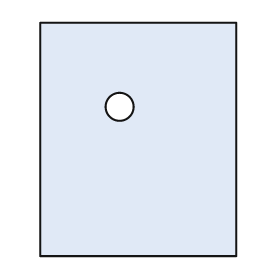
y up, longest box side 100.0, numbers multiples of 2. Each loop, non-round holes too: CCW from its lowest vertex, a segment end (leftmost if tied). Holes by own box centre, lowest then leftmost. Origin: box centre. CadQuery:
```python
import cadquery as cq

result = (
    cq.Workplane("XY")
    .moveTo(-42.0, -50.0)
    .lineTo(42.0, -50.0)
    .lineTo(42.0, 50.0)
    .lineTo(-42.0, 50.0)
    .close()
    .moveTo(-8.0, 14.0)
    .circle(6.0)
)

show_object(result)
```